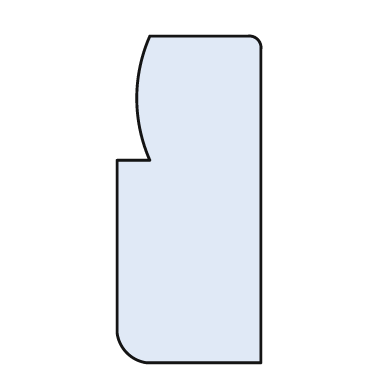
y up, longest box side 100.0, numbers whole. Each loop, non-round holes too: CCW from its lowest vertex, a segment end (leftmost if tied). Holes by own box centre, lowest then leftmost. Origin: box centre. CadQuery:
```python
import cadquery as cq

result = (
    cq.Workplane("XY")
    .moveTo(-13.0, -50.0)
    .lineTo(22.0, -50.0)
    .lineTo(22.0, 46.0)
    .threePointArc((21.0, 49.0), (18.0, 50.0))
    .lineTo(-12.0, 50.0)
    .threePointArc((-16.0, 31.0), (-12.0, 12.0))
    .lineTo(-22.0, 12.0)
    .lineTo(-22.0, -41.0)
    .threePointArc((-19.0, -47.0), (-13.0, -50.0))
    .close()
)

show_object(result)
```